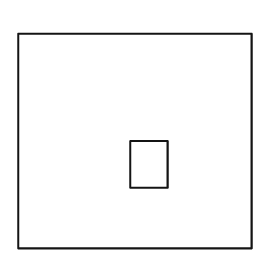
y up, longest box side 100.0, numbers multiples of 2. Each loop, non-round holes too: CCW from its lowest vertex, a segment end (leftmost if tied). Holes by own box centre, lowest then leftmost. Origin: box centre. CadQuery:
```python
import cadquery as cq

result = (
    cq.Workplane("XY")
    .moveTo(-50.0, -46.0)
    .lineTo(50.0, -46.0)
    .lineTo(50.0, 46.0)
    .lineTo(-50.0, 46.0)
    .close()
    .moveTo(-2.0, -20.0)
    .lineTo(14.0, -20.0)
    .lineTo(14.0, 0.0)
    .lineTo(-2.0, 0.0)
    .close()
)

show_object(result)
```